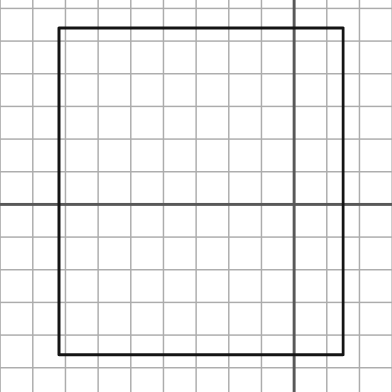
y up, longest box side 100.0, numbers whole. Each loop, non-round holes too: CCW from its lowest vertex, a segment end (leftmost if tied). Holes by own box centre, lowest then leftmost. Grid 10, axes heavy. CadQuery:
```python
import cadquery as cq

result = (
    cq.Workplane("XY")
    .moveTo(-72.0, -46.0)
    .lineTo(15.0, -46.0)
    .lineTo(15.0, 54.0)
    .lineTo(-72.0, 54.0)
    .close()
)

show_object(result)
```